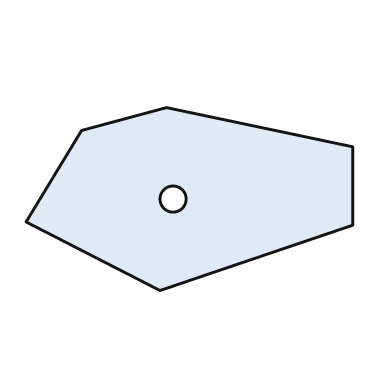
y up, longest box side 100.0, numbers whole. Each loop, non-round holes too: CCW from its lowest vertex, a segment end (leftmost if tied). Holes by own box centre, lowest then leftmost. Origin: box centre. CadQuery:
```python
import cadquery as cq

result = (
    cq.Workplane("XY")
    .moveTo(-9.0, -28.0)
    .lineTo(50.0, -8.0)
    .lineTo(50.0, 16.0)
    .lineTo(-7.0, 28.0)
    .lineTo(-33.0, 21.0)
    .lineTo(-50.0, -7.0)
    .close()
    .moveTo(-5.0, 0.0)
    .circle(4.0)
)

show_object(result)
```